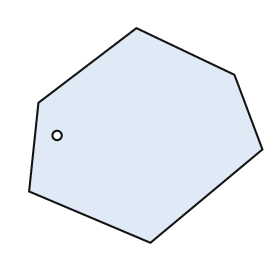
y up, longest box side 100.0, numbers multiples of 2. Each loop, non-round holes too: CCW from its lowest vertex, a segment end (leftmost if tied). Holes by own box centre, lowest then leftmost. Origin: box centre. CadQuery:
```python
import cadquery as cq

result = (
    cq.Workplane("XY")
    .moveTo(2.0, -46.0)
    .lineTo(50.0, -6.0)
    .lineTo(38.0, 26.0)
    .lineTo(-4.0, 46.0)
    .lineTo(-46.0, 14.0)
    .lineTo(-50.0, -24.0)
    .close()
    .moveTo(-38.0, 0.0)
    .circle(2.0)
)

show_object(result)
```